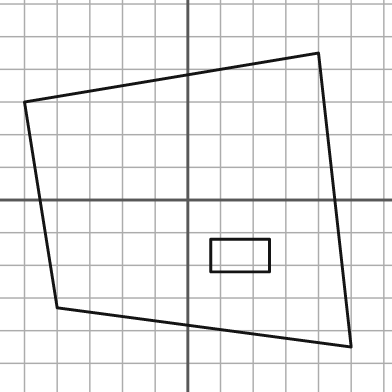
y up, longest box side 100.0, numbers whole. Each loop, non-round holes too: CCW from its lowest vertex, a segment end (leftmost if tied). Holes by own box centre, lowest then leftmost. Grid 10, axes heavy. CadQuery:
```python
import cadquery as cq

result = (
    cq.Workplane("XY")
    .moveTo(50.0, -45.0)
    .lineTo(40.0, 45.0)
    .lineTo(-50.0, 30.0)
    .lineTo(-40.0, -33.0)
    .close()
    .moveTo(7.0, -22.0)
    .lineTo(25.0, -22.0)
    .lineTo(25.0, -12.0)
    .lineTo(7.0, -12.0)
    .close()
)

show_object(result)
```